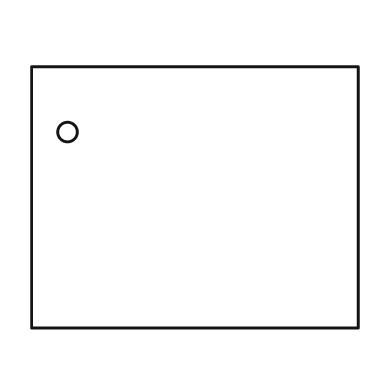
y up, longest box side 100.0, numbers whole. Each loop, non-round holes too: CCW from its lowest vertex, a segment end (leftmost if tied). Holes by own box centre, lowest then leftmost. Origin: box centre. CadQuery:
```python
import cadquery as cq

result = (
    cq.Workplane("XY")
    .moveTo(-50.0, -40.0)
    .lineTo(50.0, -40.0)
    .lineTo(50.0, 40.0)
    .lineTo(-50.0, 40.0)
    .close()
    .moveTo(-39.0, 20.0)
    .circle(3.0)
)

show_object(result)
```